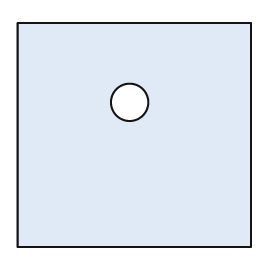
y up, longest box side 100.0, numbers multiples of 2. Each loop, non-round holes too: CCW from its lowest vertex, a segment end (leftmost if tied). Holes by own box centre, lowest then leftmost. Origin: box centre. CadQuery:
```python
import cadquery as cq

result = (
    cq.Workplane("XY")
    .moveTo(-50.0, -48.0)
    .lineTo(50.0, -48.0)
    .lineTo(50.0, 48.0)
    .lineTo(-50.0, 48.0)
    .close()
    .moveTo(-2.0, 14.0)
    .circle(8.0)
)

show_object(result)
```